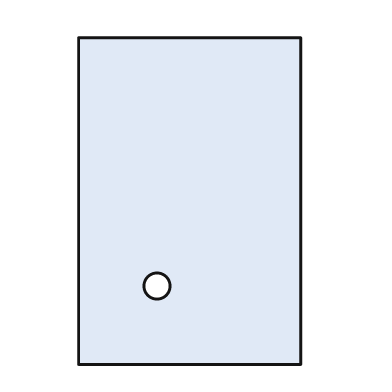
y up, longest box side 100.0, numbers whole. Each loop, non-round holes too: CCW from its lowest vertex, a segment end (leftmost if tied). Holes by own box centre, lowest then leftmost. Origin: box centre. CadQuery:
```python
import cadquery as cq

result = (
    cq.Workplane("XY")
    .moveTo(-34.0, -50.0)
    .lineTo(34.0, -50.0)
    .lineTo(34.0, 50.0)
    .lineTo(-34.0, 50.0)
    .close()
    .moveTo(-10.0, -26.0)
    .circle(4.0)
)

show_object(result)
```